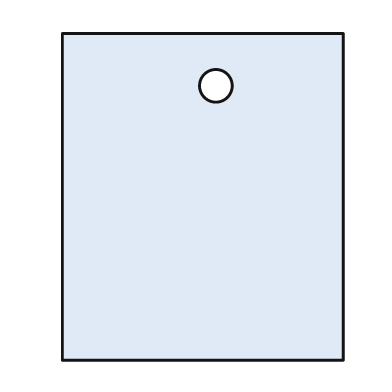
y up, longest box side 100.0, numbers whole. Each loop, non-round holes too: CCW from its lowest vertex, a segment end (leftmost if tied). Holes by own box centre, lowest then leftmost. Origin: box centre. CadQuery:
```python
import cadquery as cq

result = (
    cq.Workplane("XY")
    .moveTo(-43.0, -50.0)
    .lineTo(43.0, -50.0)
    .lineTo(43.0, 50.0)
    .lineTo(-43.0, 50.0)
    .close()
    .moveTo(4.0, 34.0)
    .circle(5.0)
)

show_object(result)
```